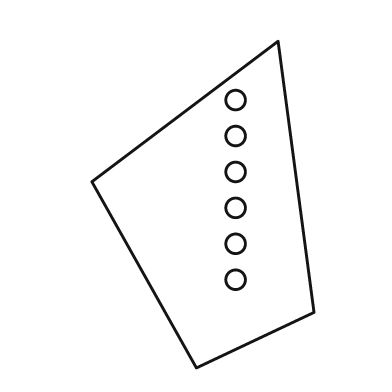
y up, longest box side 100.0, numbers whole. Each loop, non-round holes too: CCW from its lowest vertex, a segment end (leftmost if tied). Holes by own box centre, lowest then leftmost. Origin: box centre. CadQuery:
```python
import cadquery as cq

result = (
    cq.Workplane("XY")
    .moveTo(-2.0, -50.0)
    .lineTo(34.0, -33.0)
    .lineTo(23.0, 50.0)
    .lineTo(-34.0, 7.0)
    .close()
    .moveTo(10.0, -23.0)
    .circle(3.0)
    .moveTo(10.0, -12.0)
    .circle(3.0)
    .moveTo(10.0, -1.0)
    .circle(3.0)
    .moveTo(10.0, 10.0)
    .circle(3.0)
    .moveTo(10.0, 21.0)
    .circle(3.0)
    .moveTo(10.0, 32.0)
    .circle(3.0)
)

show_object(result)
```